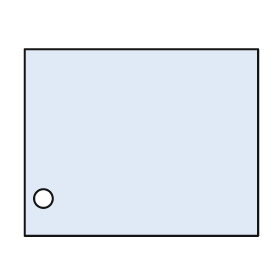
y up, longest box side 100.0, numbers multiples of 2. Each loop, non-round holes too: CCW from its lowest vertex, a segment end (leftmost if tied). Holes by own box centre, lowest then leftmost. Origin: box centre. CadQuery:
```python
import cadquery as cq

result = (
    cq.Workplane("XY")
    .moveTo(-50.0, -40.0)
    .lineTo(50.0, -40.0)
    .lineTo(50.0, 40.0)
    .lineTo(-50.0, 40.0)
    .close()
    .moveTo(-42.0, -24.0)
    .circle(4.0)
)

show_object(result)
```